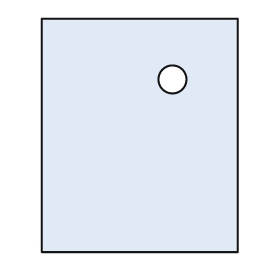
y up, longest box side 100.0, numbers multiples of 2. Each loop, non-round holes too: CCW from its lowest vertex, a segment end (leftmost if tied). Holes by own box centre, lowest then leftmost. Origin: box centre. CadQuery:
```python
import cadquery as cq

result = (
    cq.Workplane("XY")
    .moveTo(-42.0, -50.0)
    .lineTo(42.0, -50.0)
    .lineTo(42.0, 50.0)
    .lineTo(-42.0, 50.0)
    .close()
    .moveTo(14.0, 24.0)
    .circle(6.0)
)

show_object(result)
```